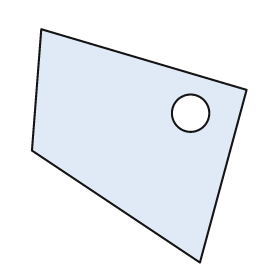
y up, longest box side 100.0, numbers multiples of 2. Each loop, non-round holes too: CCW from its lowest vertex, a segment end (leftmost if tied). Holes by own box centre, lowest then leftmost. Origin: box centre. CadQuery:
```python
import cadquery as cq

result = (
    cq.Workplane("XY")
    .moveTo(26.0, -50.0)
    .lineTo(46.0, 24.0)
    .lineTo(-42.0, 50.0)
    .lineTo(-46.0, -2.0)
    .close()
    .moveTo(22.0, 14.0)
    .circle(8.0)
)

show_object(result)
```